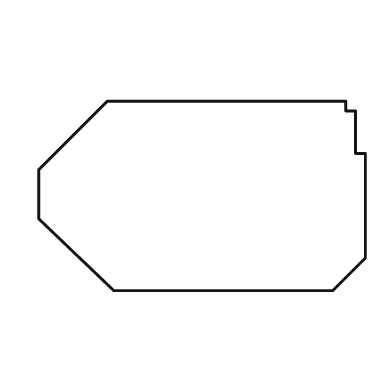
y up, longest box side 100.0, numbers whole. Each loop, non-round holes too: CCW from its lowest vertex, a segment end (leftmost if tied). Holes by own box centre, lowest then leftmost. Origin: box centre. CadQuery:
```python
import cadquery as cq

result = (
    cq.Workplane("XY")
    .moveTo(-27.0, -29.0)
    .lineTo(40.0, -29.0)
    .lineTo(50.0, -19.0)
    .lineTo(50.0, 13.0)
    .lineTo(47.0, 13.0)
    .lineTo(47.0, 26.0)
    .lineTo(44.0, 26.0)
    .lineTo(44.0, 29.0)
    .lineTo(-29.0, 29.0)
    .lineTo(-50.0, 8.0)
    .lineTo(-50.0, -7.0)
    .close()
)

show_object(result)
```